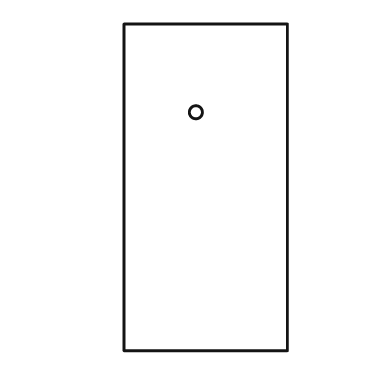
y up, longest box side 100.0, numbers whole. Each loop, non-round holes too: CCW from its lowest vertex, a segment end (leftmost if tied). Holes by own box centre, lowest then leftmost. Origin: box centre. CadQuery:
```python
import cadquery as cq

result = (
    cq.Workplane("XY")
    .moveTo(-25.0, -50.0)
    .lineTo(25.0, -50.0)
    .lineTo(25.0, 50.0)
    .lineTo(-25.0, 50.0)
    .close()
    .moveTo(-3.0, 23.0)
    .circle(2.0)
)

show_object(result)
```